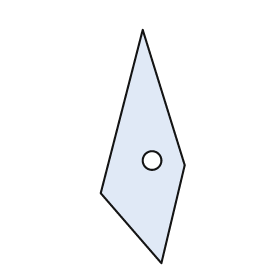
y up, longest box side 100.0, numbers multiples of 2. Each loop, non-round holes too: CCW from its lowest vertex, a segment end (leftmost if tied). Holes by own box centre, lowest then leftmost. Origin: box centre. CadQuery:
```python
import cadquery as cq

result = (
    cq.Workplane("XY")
    .moveTo(8.0, -50.0)
    .lineTo(18.0, -8.0)
    .lineTo(0.0, 50.0)
    .lineTo(-18.0, -20.0)
    .close()
    .moveTo(4.0, -6.0)
    .circle(4.0)
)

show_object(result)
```